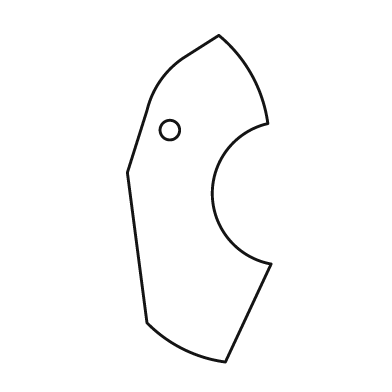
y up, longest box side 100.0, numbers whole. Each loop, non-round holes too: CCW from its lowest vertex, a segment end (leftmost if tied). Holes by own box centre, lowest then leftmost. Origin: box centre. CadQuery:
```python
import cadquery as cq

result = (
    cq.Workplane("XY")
    .moveTo(8.0, -50.0)
    .lineTo(22.0, -20.0)
    .threePointArc((4.0, 1.0), (21.0, 23.0))
    .threePointArc((16.0, 38.0), (6.0, 50.0))
    .lineTo(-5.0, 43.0)
    .threePointArc((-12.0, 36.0), (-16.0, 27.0))
    .lineTo(-22.0, 8.0)
    .lineTo(-16.0, -38.0)
    .threePointArc((-5.0, -46.0), (8.0, -50.0))
    .close()
    .moveTo(-9.0, 21.0)
    .circle(3.0)
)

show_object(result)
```